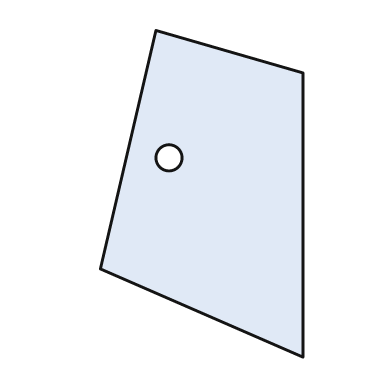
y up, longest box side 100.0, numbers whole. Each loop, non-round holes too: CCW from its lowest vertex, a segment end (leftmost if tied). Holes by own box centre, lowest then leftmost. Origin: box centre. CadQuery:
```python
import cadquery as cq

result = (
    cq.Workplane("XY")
    .moveTo(31.0, -50.0)
    .lineTo(31.0, 37.0)
    .lineTo(-14.0, 50.0)
    .lineTo(-31.0, -23.0)
    .close()
    .moveTo(-10.0, 11.0)
    .circle(4.0)
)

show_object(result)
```